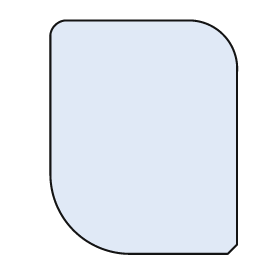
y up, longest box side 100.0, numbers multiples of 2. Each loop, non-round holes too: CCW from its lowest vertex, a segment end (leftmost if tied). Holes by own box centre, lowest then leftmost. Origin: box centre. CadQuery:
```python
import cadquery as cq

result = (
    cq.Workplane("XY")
    .moveTo(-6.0, -50.0)
    .lineTo(36.0, -50.0)
    .lineTo(40.0, -46.0)
    .lineTo(40.0, 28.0)
    .threePointArc((34.0, 44.0), (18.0, 50.0))
    .lineTo(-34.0, 50.0)
    .threePointArc((-38.0, 48.0), (-40.0, 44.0))
    .lineTo(-40.0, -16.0)
    .threePointArc((-30.0, -40.0), (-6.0, -50.0))
    .close()
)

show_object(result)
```